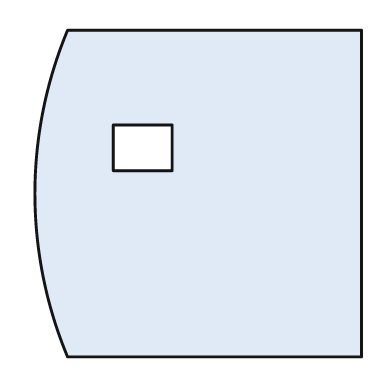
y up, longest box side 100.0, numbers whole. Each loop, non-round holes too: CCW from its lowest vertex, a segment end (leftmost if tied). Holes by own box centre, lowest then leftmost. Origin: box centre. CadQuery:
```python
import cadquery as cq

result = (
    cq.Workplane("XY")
    .moveTo(-40.0, -50.0)
    .lineTo(50.0, -50.0)
    .lineTo(50.0, 50.0)
    .lineTo(-40.0, 50.0)
    .threePointArc((-50.0, 0.0), (-40.0, -50.0))
    .close()
    .moveTo(-26.0, 7.0)
    .lineTo(-8.0, 7.0)
    .lineTo(-8.0, 21.0)
    .lineTo(-26.0, 21.0)
    .close()
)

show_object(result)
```